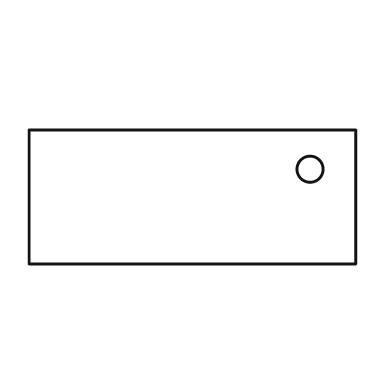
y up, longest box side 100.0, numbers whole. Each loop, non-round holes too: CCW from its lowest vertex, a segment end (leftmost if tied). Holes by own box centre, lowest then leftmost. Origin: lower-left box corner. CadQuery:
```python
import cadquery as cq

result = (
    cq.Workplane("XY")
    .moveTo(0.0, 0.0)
    .lineTo(100.0, 0.0)
    .lineTo(100.0, 41.0)
    .lineTo(0.0, 41.0)
    .close()
    .moveTo(86.0, 29.0)
    .circle(4.0)
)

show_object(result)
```